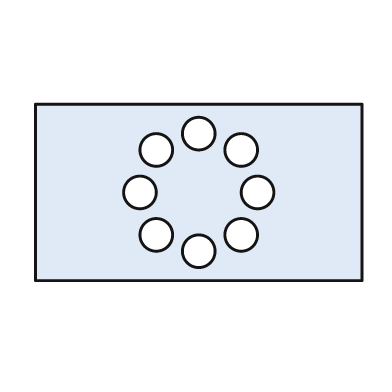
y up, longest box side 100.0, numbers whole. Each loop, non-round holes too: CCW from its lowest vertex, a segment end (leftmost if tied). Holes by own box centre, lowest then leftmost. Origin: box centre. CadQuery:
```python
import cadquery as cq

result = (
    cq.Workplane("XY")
    .moveTo(-50.0, -27.0)
    .lineTo(50.0, -27.0)
    .lineTo(50.0, 27.0)
    .lineTo(-50.0, 27.0)
    .close()
    .moveTo(0.0, -18.0)
    .circle(5.0)
    .moveTo(-13.0, -13.0)
    .circle(5.0)
    .moveTo(13.0, -13.0)
    .circle(5.0)
    .moveTo(-18.0, 0.0)
    .circle(5.0)
    .moveTo(18.0, 0.0)
    .circle(5.0)
    .moveTo(-13.0, 13.0)
    .circle(5.0)
    .moveTo(13.0, 13.0)
    .circle(5.0)
    .moveTo(0.0, 18.0)
    .circle(5.0)
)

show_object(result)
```